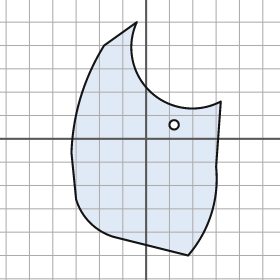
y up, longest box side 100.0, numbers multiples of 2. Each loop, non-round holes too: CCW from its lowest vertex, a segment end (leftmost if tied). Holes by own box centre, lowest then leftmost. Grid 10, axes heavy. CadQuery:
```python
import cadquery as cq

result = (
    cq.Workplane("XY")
    .moveTo(18.0, -50.0)
    .threePointArc((28.0, -32.0), (30.0, -12.0))
    .lineTo(32.0, 16.0)
    .threePointArc((2.0, 20.0), (-4.0, 50.0))
    .lineTo(-18.0, 40.0)
    .threePointArc((-28.0, 18.0), (-32.0, -6.0))
    .lineTo(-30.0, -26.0)
    .threePointArc((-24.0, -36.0), (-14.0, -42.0))
    .close()
    .moveTo(12.0, 6.0)
    .circle(2.0)
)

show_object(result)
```